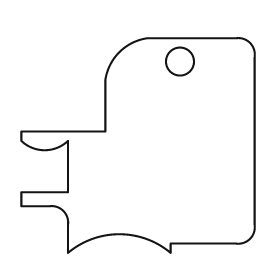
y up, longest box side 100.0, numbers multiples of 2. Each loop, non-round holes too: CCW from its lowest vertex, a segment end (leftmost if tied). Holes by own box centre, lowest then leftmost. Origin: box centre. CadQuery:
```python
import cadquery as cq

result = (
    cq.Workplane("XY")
    .moveTo(-30.0, -46.0)
    .threePointArc((-8.0, -38.0), (14.0, -46.0))
    .lineTo(14.0, -42.0)
    .lineTo(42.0, -42.0)
    .threePointArc((48.0, -40.0), (50.0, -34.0))
    .lineTo(50.0, 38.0)
    .threePointArc((48.0, 44.0), (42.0, 46.0))
    .lineTo(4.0, 46.0)
    .threePointArc((-8.0, 40.0), (-14.0, 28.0))
    .lineTo(-14.0, 6.0)
    .lineTo(-50.0, 6.0)
    .lineTo(-50.0, 2.0)
    .threePointArc((-40.0, -2.0), (-30.0, 2.0))
    .lineTo(-30.0, -20.0)
    .lineTo(-50.0, -20.0)
    .lineTo(-50.0, -26.0)
    .lineTo(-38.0, -26.0)
    .threePointArc((-32.0, -28.0), (-30.0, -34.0))
    .close()
    .moveTo(18.0, 36.0)
    .circle(6.0)
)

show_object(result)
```